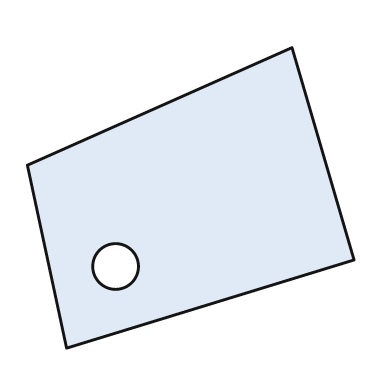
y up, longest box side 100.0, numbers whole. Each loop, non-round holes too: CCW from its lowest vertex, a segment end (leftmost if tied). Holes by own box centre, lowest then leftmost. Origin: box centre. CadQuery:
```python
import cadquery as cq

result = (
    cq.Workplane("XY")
    .moveTo(-38.0, -46.0)
    .lineTo(50.0, -19.0)
    .lineTo(31.0, 46.0)
    .lineTo(-50.0, 10.0)
    .close()
    .moveTo(-23.0, -21.0)
    .circle(7.0)
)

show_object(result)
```